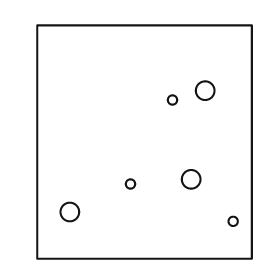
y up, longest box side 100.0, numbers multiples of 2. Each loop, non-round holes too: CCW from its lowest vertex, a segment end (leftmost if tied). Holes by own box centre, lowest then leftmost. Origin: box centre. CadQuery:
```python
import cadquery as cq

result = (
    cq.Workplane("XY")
    .moveTo(-46.0, -50.0)
    .lineTo(46.0, -50.0)
    .lineTo(46.0, 50.0)
    .lineTo(-46.0, 50.0)
    .close()
    .moveTo(38.0, -34.0)
    .circle(2.0)
    .moveTo(-32.0, -30.0)
    .circle(4.0)
    .moveTo(-6.0, -18.0)
    .circle(2.0)
    .moveTo(20.0, -16.0)
    .circle(4.0)
    .moveTo(12.0, 18.0)
    .circle(2.0)
    .moveTo(26.0, 22.0)
    .circle(4.0)
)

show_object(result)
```